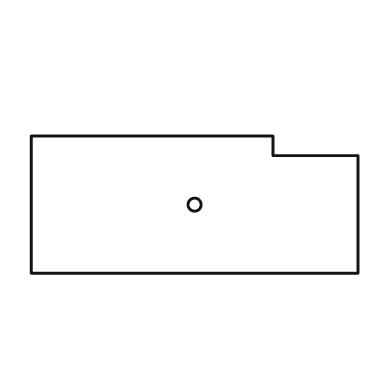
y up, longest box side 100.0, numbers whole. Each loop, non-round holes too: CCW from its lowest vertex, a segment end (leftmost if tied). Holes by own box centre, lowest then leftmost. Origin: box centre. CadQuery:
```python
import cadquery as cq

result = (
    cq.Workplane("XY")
    .moveTo(-50.0, -21.0)
    .lineTo(50.0, -21.0)
    .lineTo(50.0, 15.0)
    .lineTo(24.0, 15.0)
    .lineTo(24.0, 21.0)
    .lineTo(-50.0, 21.0)
    .close()
    .moveTo(0.0, 0.0)
    .circle(2.0)
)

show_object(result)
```